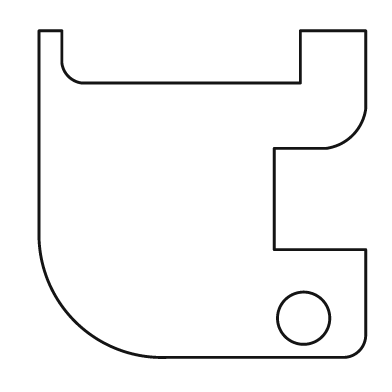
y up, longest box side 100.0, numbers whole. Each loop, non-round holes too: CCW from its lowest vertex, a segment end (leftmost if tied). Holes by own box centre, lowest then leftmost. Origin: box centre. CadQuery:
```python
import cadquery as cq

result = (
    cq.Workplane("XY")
    .moveTo(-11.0, -50.0)
    .lineTo(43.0, -50.0)
    .threePointArc((48.0, -48.0), (50.0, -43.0))
    .lineTo(50.0, -17.0)
    .lineTo(22.0, -17.0)
    .lineTo(22.0, 14.0)
    .lineTo(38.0, 14.0)
    .threePointArc((46.0, 18.0), (50.0, 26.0))
    .lineTo(50.0, 50.0)
    .lineTo(30.0, 50.0)
    .lineTo(30.0, 34.0)
    .lineTo(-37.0, 34.0)
    .threePointArc((-41.0, 36.0), (-43.0, 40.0))
    .lineTo(-43.0, 50.0)
    .lineTo(-50.0, 50.0)
    .lineTo(-50.0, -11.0)
    .threePointArc((-39.0, -39.0), (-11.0, -50.0))
    .close()
    .moveTo(31.0, -38.0)
    .circle(8.0)
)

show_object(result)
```